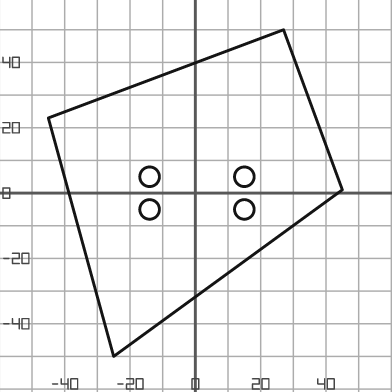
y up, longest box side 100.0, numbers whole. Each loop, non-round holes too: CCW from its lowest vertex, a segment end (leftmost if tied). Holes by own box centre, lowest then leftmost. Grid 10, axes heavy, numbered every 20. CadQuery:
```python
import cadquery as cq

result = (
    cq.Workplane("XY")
    .moveTo(-25.0, -50.0)
    .lineTo(45.0, 1.0)
    .lineTo(27.0, 50.0)
    .lineTo(-45.0, 23.0)
    .close()
    .moveTo(-14.0, -5.0)
    .circle(3.0)
    .moveTo(15.0, -5.0)
    .circle(3.0)
    .moveTo(-14.0, 5.0)
    .circle(3.0)
    .moveTo(15.0, 5.0)
    .circle(3.0)
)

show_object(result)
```